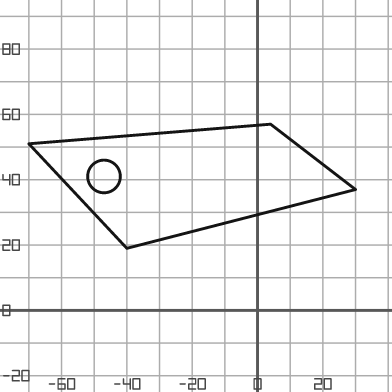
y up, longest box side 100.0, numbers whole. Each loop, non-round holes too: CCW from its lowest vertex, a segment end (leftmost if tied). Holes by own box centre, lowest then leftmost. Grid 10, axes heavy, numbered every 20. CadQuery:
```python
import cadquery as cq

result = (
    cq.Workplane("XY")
    .moveTo(-40.0, 19.0)
    .lineTo(30.0, 37.0)
    .lineTo(4.0, 57.0)
    .lineTo(-70.0, 51.0)
    .close()
    .moveTo(-47.0, 41.0)
    .circle(5.0)
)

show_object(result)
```